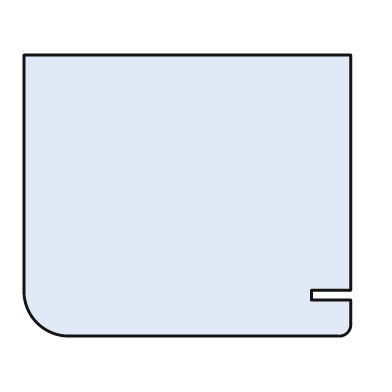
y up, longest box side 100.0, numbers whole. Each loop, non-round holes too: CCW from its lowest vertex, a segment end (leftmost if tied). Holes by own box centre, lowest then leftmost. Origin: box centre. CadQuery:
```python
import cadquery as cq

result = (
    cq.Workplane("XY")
    .moveTo(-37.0, -43.0)
    .lineTo(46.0, -43.0)
    .threePointArc((49.0, -42.0), (50.0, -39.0))
    .lineTo(50.0, -32.0)
    .lineTo(38.0, -32.0)
    .lineTo(38.0, -29.0)
    .lineTo(50.0, -29.0)
    .lineTo(50.0, 43.0)
    .lineTo(-50.0, 43.0)
    .lineTo(-50.0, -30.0)
    .threePointArc((-46.0, -39.0), (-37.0, -43.0))
    .close()
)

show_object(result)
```